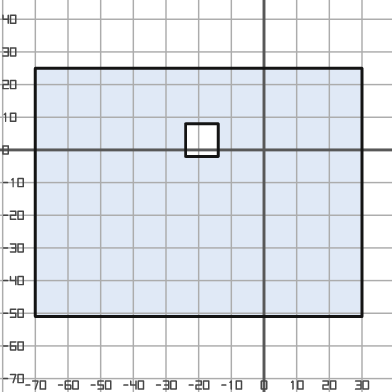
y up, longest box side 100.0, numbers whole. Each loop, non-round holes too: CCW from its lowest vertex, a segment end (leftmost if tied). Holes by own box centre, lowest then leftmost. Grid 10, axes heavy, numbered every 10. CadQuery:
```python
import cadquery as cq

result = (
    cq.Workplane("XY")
    .moveTo(-70.0, -51.0)
    .lineTo(30.0, -51.0)
    .lineTo(30.0, 25.0)
    .lineTo(-70.0, 25.0)
    .close()
    .moveTo(-24.0, -2.0)
    .lineTo(-14.0, -2.0)
    .lineTo(-14.0, 8.0)
    .lineTo(-24.0, 8.0)
    .close()
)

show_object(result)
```